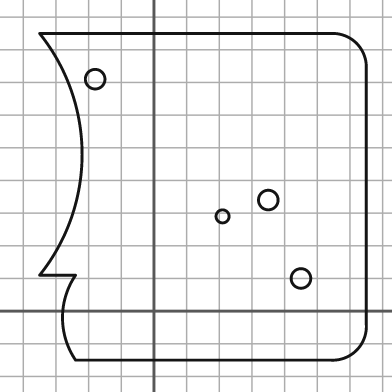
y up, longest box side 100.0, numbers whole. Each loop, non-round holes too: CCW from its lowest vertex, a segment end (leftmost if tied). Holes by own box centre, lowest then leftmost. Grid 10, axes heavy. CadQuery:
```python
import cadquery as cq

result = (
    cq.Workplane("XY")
    .moveTo(-24.0, -15.0)
    .lineTo(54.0, -15.0)
    .threePointArc((62.0, -12.0), (65.0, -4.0))
    .lineTo(65.0, 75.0)
    .threePointArc((62.0, 82.0), (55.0, 85.0))
    .lineTo(-35.0, 85.0)
    .threePointArc((-22.0, 48.0), (-35.0, 11.0))
    .lineTo(-24.0, 11.0)
    .threePointArc((-28.0, -2.0), (-24.0, -15.0))
    .close()
    .moveTo(45.0, 10.0)
    .circle(3.0)
    .moveTo(21.0, 29.0)
    .circle(2.0)
    .moveTo(35.0, 34.0)
    .circle(3.0)
    .moveTo(-18.0, 71.0)
    .circle(3.0)
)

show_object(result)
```